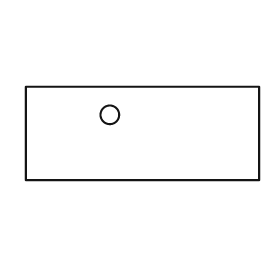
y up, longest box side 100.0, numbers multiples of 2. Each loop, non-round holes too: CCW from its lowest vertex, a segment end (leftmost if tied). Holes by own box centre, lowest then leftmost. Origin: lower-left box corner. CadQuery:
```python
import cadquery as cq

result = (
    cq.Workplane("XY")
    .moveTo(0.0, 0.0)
    .lineTo(100.0, 0.0)
    .lineTo(100.0, 40.0)
    .lineTo(0.0, 40.0)
    .close()
    .moveTo(36.0, 28.0)
    .circle(4.0)
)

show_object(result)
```